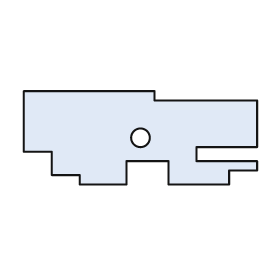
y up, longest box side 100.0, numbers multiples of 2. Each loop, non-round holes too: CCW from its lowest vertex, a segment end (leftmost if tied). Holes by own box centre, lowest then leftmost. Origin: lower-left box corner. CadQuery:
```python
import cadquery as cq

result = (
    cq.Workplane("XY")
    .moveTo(24.0, 0.0)
    .lineTo(44.0, 0.0)
    .lineTo(44.0, 10.0)
    .lineTo(62.0, 10.0)
    .lineTo(62.0, 0.0)
    .lineTo(88.0, 0.0)
    .lineTo(88.0, 6.0)
    .lineTo(100.0, 6.0)
    .lineTo(100.0, 10.0)
    .lineTo(74.0, 10.0)
    .lineTo(74.0, 16.0)
    .lineTo(100.0, 16.0)
    .lineTo(100.0, 36.0)
    .lineTo(56.0, 36.0)
    .lineTo(56.0, 40.0)
    .lineTo(0.0, 40.0)
    .lineTo(0.0, 14.0)
    .lineTo(12.0, 14.0)
    .lineTo(12.0, 4.0)
    .lineTo(24.0, 4.0)
    .close()
    .moveTo(50.0, 20.0)
    .circle(4.0)
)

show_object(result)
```